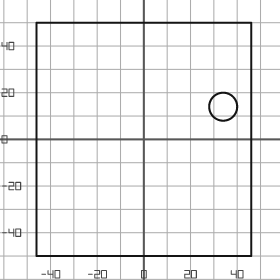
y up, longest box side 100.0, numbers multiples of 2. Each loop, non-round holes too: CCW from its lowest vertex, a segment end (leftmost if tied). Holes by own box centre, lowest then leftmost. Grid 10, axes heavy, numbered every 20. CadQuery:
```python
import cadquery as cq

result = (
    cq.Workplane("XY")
    .moveTo(-46.0, -50.0)
    .lineTo(46.0, -50.0)
    .lineTo(46.0, 50.0)
    .lineTo(-46.0, 50.0)
    .close()
    .moveTo(34.0, 14.0)
    .circle(6.0)
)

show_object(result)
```